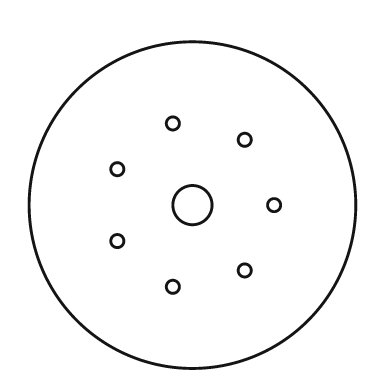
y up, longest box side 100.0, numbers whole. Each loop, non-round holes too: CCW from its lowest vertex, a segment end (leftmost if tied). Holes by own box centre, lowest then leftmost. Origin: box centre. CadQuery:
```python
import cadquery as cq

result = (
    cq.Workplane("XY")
    .moveTo(0.0, 0.0)
    .circle(50.0)
    .moveTo(-6.0, -25.0)
    .circle(2.0)
    .moveTo(16.0, -20.0)
    .circle(2.0)
    .moveTo(-23.0, -11.0)
    .circle(2.0)
    .moveTo(0.0, 0.0)
    .circle(6.0)
    .moveTo(25.0, 0.0)
    .circle(2.0)
    .moveTo(-23.0, 11.0)
    .circle(2.0)
    .moveTo(16.0, 20.0)
    .circle(2.0)
    .moveTo(-6.0, 25.0)
    .circle(2.0)
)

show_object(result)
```